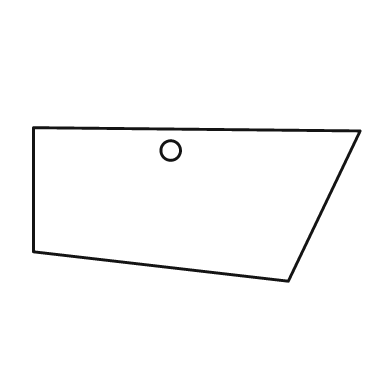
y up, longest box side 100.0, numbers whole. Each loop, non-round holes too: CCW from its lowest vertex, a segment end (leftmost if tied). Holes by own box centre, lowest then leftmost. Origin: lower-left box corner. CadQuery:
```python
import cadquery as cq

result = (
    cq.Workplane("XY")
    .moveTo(78.0, 0.0)
    .lineTo(100.0, 46.0)
    .lineTo(0.0, 47.0)
    .lineTo(0.0, 9.0)
    .close()
    .moveTo(42.0, 40.0)
    .circle(3.0)
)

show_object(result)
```